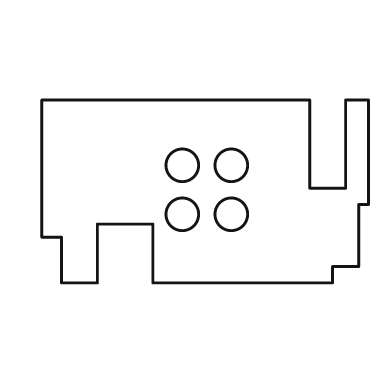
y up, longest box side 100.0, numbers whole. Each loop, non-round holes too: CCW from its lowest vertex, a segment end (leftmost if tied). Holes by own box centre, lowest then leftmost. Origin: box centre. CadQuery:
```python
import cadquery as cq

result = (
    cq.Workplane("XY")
    .moveTo(-44.0, -28.0)
    .lineTo(-33.0, -28.0)
    .lineTo(-33.0, -10.0)
    .lineTo(-16.0, -10.0)
    .lineTo(-16.0, -28.0)
    .lineTo(39.0, -28.0)
    .lineTo(39.0, -23.0)
    .lineTo(47.0, -23.0)
    .lineTo(47.0, -4.0)
    .lineTo(50.0, -4.0)
    .lineTo(50.0, 28.0)
    .lineTo(43.0, 28.0)
    .lineTo(43.0, 1.0)
    .lineTo(32.0, 1.0)
    .lineTo(32.0, 28.0)
    .lineTo(-50.0, 28.0)
    .lineTo(-50.0, -14.0)
    .lineTo(-44.0, -14.0)
    .close()
    .moveTo(-7.0, -7.0)
    .circle(5.0)
    .moveTo(8.0, -7.0)
    .circle(5.0)
    .moveTo(-7.0, 8.0)
    .circle(5.0)
    .moveTo(8.0, 8.0)
    .circle(5.0)
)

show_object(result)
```